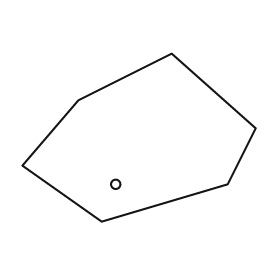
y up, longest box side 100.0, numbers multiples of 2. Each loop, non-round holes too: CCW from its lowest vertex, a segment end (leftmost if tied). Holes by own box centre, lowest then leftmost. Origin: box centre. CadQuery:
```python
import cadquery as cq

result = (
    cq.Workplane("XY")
    .moveTo(-16.0, -36.0)
    .lineTo(38.0, -20.0)
    .lineTo(50.0, 4.0)
    .lineTo(14.0, 36.0)
    .lineTo(-26.0, 16.0)
    .lineTo(-50.0, -12.0)
    .close()
    .moveTo(-10.0, -20.0)
    .circle(2.0)
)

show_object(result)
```